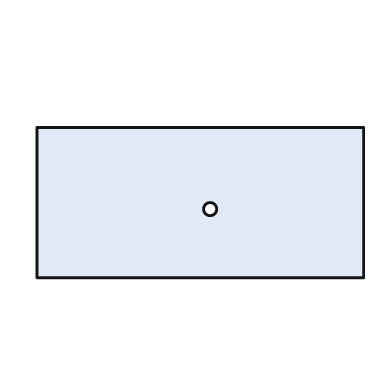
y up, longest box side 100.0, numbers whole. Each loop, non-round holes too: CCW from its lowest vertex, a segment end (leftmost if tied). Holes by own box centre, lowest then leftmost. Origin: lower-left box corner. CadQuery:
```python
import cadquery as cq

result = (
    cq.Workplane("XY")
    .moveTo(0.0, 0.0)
    .lineTo(100.0, 0.0)
    .lineTo(100.0, 46.0)
    .lineTo(0.0, 46.0)
    .close()
    .moveTo(53.0, 21.0)
    .circle(2.0)
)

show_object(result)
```